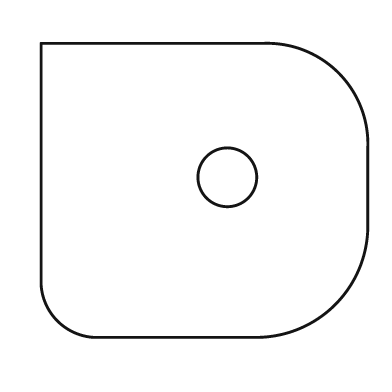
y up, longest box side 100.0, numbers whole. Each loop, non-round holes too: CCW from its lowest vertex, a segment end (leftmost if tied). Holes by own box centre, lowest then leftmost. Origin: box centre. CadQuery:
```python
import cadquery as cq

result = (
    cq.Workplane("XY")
    .moveTo(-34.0, -45.0)
    .lineTo(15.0, -45.0)
    .threePointArc((40.0, -35.0), (50.0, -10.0))
    .lineTo(50.0, 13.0)
    .threePointArc((41.0, 36.0), (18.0, 45.0))
    .lineTo(-50.0, 45.0)
    .lineTo(-50.0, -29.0)
    .threePointArc((-45.0, -40.0), (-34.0, -45.0))
    .close()
    .moveTo(7.0, 4.0)
    .circle(9.0)
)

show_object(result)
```